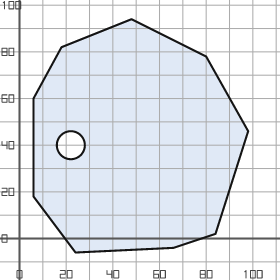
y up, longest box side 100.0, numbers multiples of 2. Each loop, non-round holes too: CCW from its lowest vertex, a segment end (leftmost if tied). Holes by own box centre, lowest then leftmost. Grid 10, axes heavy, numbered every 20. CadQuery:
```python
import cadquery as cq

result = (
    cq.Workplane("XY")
    .moveTo(24.0, -6.0)
    .lineTo(66.0, -4.0)
    .lineTo(84.0, 2.0)
    .lineTo(98.0, 46.0)
    .lineTo(80.0, 78.0)
    .lineTo(48.0, 94.0)
    .lineTo(18.0, 82.0)
    .lineTo(6.0, 60.0)
    .lineTo(6.0, 18.0)
    .close()
    .moveTo(22.0, 40.0)
    .circle(6.0)
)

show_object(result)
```